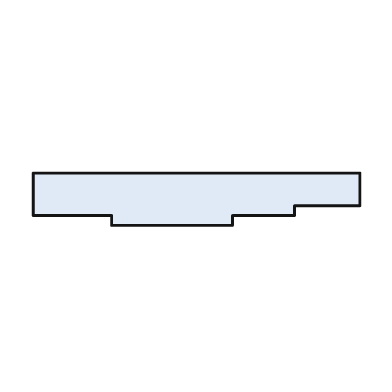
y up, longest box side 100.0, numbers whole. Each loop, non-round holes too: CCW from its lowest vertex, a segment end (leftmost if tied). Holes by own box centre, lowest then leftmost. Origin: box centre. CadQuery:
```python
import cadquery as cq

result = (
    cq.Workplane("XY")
    .moveTo(-26.0, -8.0)
    .lineTo(11.0, -8.0)
    .lineTo(11.0, -5.0)
    .lineTo(30.0, -5.0)
    .lineTo(30.0, -2.0)
    .lineTo(50.0, -2.0)
    .lineTo(50.0, 8.0)
    .lineTo(-50.0, 8.0)
    .lineTo(-50.0, -5.0)
    .lineTo(-26.0, -5.0)
    .close()
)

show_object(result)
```